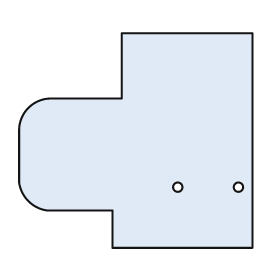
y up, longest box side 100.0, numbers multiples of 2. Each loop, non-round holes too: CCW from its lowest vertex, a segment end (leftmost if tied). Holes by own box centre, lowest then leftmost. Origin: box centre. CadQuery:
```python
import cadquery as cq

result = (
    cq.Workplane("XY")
    .moveTo(-10.0, -46.0)
    .lineTo(50.0, -46.0)
    .lineTo(50.0, 46.0)
    .lineTo(-6.0, 46.0)
    .lineTo(-6.0, 18.0)
    .lineTo(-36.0, 18.0)
    .threePointArc((-46.0, 14.0), (-50.0, 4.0))
    .lineTo(-50.0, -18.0)
    .threePointArc((-46.0, -26.0), (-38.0, -30.0))
    .lineTo(-10.0, -30.0)
    .close()
    .moveTo(18.0, -20.0)
    .circle(2.0)
    .moveTo(44.0, -20.0)
    .circle(2.0)
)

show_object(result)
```